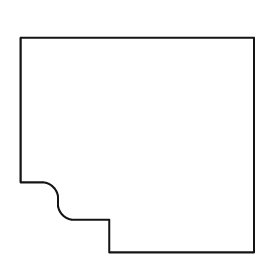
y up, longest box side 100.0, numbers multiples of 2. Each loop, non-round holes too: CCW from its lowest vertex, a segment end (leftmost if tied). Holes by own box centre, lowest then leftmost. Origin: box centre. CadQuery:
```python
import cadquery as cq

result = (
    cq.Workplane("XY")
    .moveTo(-12.0, -46.0)
    .lineTo(50.0, -46.0)
    .lineTo(50.0, 46.0)
    .lineTo(-50.0, 46.0)
    .lineTo(-50.0, -16.0)
    .lineTo(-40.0, -16.0)
    .threePointArc((-36.0, -18.0), (-34.0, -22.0))
    .lineTo(-34.0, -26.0)
    .threePointArc((-32.0, -30.0), (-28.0, -32.0))
    .lineTo(-12.0, -32.0)
    .close()
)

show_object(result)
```